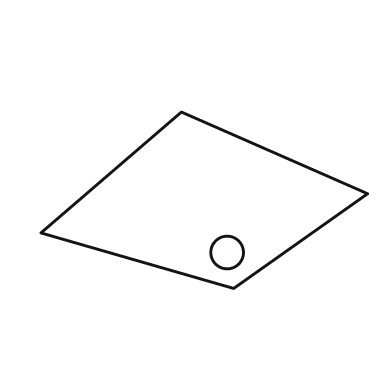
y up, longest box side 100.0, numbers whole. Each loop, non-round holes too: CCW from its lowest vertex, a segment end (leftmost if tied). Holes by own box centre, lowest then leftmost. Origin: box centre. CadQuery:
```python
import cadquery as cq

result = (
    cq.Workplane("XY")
    .moveTo(9.0, -27.0)
    .lineTo(50.0, 2.0)
    .lineTo(-7.0, 27.0)
    .lineTo(-50.0, -10.0)
    .close()
    .moveTo(7.0, -16.0)
    .circle(5.0)
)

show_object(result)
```